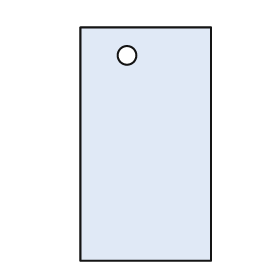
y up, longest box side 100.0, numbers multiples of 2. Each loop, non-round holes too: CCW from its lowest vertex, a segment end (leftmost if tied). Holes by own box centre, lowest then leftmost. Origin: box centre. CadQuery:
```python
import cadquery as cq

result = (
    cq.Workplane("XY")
    .moveTo(-28.0, -50.0)
    .lineTo(28.0, -50.0)
    .lineTo(28.0, 50.0)
    .lineTo(-28.0, 50.0)
    .close()
    .moveTo(-8.0, 38.0)
    .circle(4.0)
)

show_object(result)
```